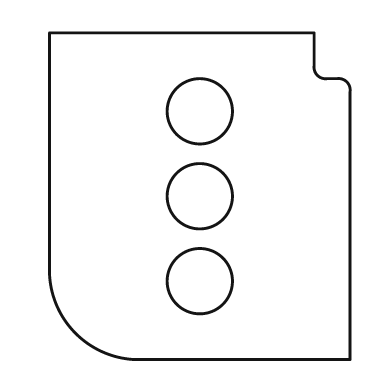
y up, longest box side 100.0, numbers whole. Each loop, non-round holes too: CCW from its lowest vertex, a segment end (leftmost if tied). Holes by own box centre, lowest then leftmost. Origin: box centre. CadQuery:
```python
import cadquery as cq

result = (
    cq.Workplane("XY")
    .moveTo(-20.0, -50.0)
    .lineTo(46.0, -50.0)
    .lineTo(46.0, 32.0)
    .threePointArc((45.0, 35.0), (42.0, 36.0))
    .lineTo(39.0, 36.0)
    .threePointArc((36.0, 37.0), (35.0, 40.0))
    .lineTo(35.0, 50.0)
    .lineTo(-46.0, 50.0)
    .lineTo(-46.0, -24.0)
    .threePointArc((-38.0, -42.0), (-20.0, -50.0))
    .close()
    .moveTo(0.0, -26.0)
    .circle(10.0)
    .moveTo(0.0, 0.0)
    .circle(10.0)
    .moveTo(0.0, 26.0)
    .circle(10.0)
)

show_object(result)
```